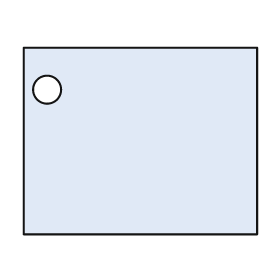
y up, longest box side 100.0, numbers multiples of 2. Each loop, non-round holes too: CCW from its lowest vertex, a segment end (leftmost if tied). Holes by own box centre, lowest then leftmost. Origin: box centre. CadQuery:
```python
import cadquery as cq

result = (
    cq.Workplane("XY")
    .moveTo(-50.0, -40.0)
    .lineTo(50.0, -40.0)
    .lineTo(50.0, 40.0)
    .lineTo(-50.0, 40.0)
    .close()
    .moveTo(-40.0, 22.0)
    .circle(6.0)
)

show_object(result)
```